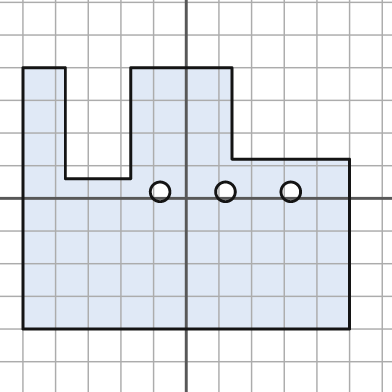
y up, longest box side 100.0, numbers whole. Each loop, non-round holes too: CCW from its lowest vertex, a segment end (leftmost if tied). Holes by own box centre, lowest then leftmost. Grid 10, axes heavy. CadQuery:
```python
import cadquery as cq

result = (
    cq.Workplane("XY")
    .moveTo(-50.0, -40.0)
    .lineTo(50.0, -40.0)
    .lineTo(50.0, 12.0)
    .lineTo(14.0, 12.0)
    .lineTo(14.0, 40.0)
    .lineTo(-17.0, 40.0)
    .lineTo(-17.0, 6.0)
    .lineTo(-37.0, 6.0)
    .lineTo(-37.0, 40.0)
    .lineTo(-50.0, 40.0)
    .close()
    .moveTo(-8.0, 2.0)
    .circle(3.0)
    .moveTo(12.0, 2.0)
    .circle(3.0)
    .moveTo(32.0, 2.0)
    .circle(3.0)
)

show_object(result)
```